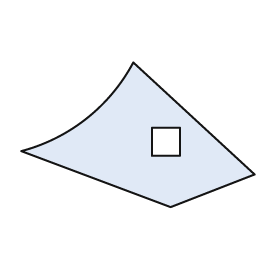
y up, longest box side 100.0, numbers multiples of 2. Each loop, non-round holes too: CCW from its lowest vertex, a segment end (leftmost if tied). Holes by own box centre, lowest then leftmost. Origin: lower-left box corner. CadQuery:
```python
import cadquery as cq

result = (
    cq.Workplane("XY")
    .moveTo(64.0, 0.0)
    .lineTo(100.0, 14.0)
    .lineTo(48.0, 62.0)
    .threePointArc((28.0, 38.0), (0.0, 24.0))
    .close()
    .moveTo(56.0, 22.0)
    .lineTo(68.0, 22.0)
    .lineTo(68.0, 34.0)
    .lineTo(56.0, 34.0)
    .close()
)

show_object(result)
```